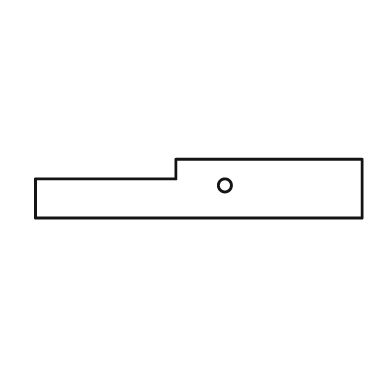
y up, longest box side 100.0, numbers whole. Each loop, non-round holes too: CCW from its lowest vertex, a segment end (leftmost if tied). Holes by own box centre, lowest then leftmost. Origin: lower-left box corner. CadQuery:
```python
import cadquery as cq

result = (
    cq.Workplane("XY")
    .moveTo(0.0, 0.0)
    .lineTo(100.0, 0.0)
    .lineTo(100.0, 18.0)
    .lineTo(43.0, 18.0)
    .lineTo(43.0, 12.0)
    .lineTo(0.0, 12.0)
    .close()
    .moveTo(58.0, 10.0)
    .circle(2.0)
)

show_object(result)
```